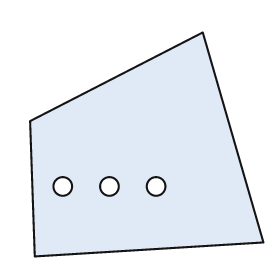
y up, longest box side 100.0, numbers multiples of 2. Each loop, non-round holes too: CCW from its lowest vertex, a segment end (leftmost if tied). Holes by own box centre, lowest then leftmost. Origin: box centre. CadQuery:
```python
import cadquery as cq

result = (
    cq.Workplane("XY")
    .moveTo(-48.0, -48.0)
    .lineTo(50.0, -42.0)
    .lineTo(24.0, 48.0)
    .lineTo(-50.0, 10.0)
    .close()
    .moveTo(-36.0, -18.0)
    .circle(4.0)
    .moveTo(-16.0, -18.0)
    .circle(4.0)
    .moveTo(4.0, -18.0)
    .circle(4.0)
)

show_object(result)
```